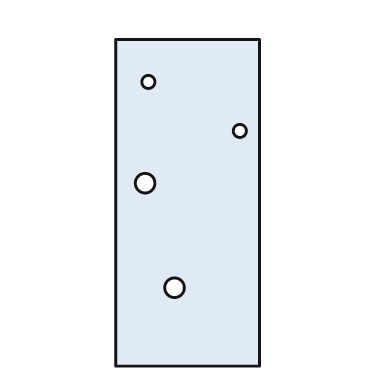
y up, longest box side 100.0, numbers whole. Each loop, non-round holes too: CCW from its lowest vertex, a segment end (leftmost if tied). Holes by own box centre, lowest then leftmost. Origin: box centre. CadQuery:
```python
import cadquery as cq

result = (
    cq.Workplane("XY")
    .moveTo(-22.0, -50.0)
    .lineTo(22.0, -50.0)
    .lineTo(22.0, 50.0)
    .lineTo(-22.0, 50.0)
    .close()
    .moveTo(-4.0, -26.0)
    .circle(3.0)
    .moveTo(-13.0, 6.0)
    .circle(3.0)
    .moveTo(16.0, 22.0)
    .circle(2.0)
    .moveTo(-12.0, 37.0)
    .circle(2.0)
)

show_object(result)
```